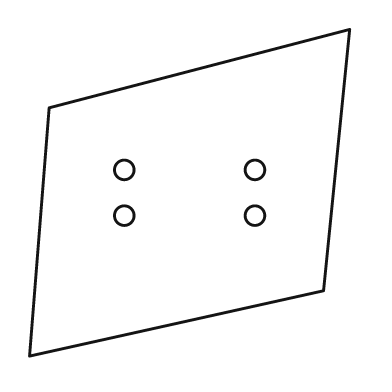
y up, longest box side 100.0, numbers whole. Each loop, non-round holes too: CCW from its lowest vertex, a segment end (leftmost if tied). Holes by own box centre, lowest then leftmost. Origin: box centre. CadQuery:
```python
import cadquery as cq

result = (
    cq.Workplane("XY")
    .moveTo(-49.0, -50.0)
    .lineTo(41.0, -30.0)
    .lineTo(49.0, 50.0)
    .lineTo(-43.0, 26.0)
    .close()
    .moveTo(-20.0, -7.0)
    .circle(3.0)
    .moveTo(20.0, -7.0)
    .circle(3.0)
    .moveTo(-20.0, 7.0)
    .circle(3.0)
    .moveTo(20.0, 7.0)
    .circle(3.0)
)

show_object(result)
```